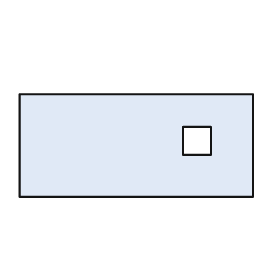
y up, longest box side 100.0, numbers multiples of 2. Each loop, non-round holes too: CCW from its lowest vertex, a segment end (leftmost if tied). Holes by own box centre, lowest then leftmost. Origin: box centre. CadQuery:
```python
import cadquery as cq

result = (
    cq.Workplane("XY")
    .moveTo(-50.0, -22.0)
    .lineTo(50.0, -22.0)
    .lineTo(50.0, 22.0)
    .lineTo(-50.0, 22.0)
    .close()
    .moveTo(20.0, -4.0)
    .lineTo(32.0, -4.0)
    .lineTo(32.0, 8.0)
    .lineTo(20.0, 8.0)
    .close()
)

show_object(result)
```